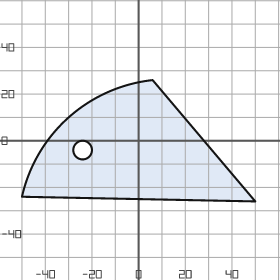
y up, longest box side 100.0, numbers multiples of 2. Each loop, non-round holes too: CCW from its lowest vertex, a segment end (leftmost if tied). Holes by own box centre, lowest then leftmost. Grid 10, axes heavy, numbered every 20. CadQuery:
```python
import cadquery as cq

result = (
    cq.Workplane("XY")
    .moveTo(50.0, -26.0)
    .lineTo(6.0, 26.0)
    .threePointArc((-30.0, 10.0), (-50.0, -24.0))
    .close()
    .moveTo(-24.0, -4.0)
    .circle(4.0)
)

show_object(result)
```